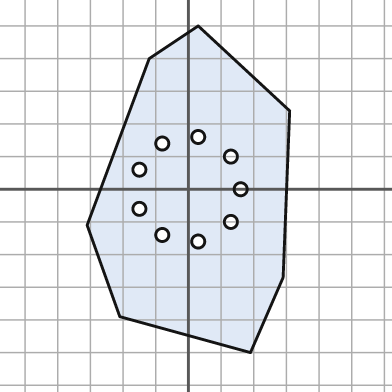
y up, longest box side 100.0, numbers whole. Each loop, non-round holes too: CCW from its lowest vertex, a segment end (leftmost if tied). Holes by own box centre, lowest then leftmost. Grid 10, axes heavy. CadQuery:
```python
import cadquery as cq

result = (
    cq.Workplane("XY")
    .moveTo(19.0, -50.0)
    .lineTo(29.0, -27.0)
    .lineTo(31.0, 24.0)
    .lineTo(3.0, 50.0)
    .lineTo(-12.0, 40.0)
    .lineTo(-31.0, -11.0)
    .lineTo(-21.0, -39.0)
    .close()
    .moveTo(3.0, -16.0)
    .circle(2.0)
    .moveTo(-8.0, -14.0)
    .circle(2.0)
    .moveTo(13.0, -10.0)
    .circle(2.0)
    .moveTo(-15.0, -6.0)
    .circle(2.0)
    .moveTo(16.0, 0.0)
    .circle(2.0)
    .moveTo(-15.0, 6.0)
    .circle(2.0)
    .moveTo(13.0, 10.0)
    .circle(2.0)
    .moveTo(-8.0, 14.0)
    .circle(2.0)
    .moveTo(3.0, 16.0)
    .circle(2.0)
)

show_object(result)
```